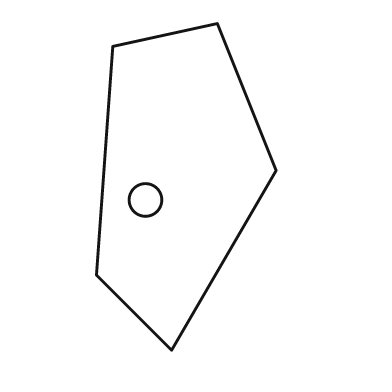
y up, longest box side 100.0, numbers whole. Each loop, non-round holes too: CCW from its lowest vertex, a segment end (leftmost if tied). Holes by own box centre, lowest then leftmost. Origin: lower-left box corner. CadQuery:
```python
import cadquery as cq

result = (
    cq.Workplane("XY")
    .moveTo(23.0, 0.0)
    .lineTo(55.0, 55.0)
    .lineTo(37.0, 100.0)
    .lineTo(5.0, 93.0)
    .lineTo(0.0, 23.0)
    .close()
    .moveTo(15.0, 46.0)
    .circle(5.0)
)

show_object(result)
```